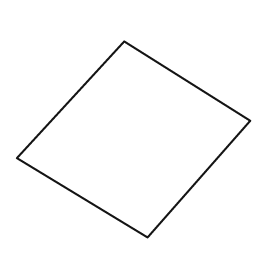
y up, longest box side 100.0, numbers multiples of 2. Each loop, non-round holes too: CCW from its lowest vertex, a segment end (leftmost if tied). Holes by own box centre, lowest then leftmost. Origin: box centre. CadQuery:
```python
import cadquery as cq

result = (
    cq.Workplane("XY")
    .moveTo(6.0, -42.0)
    .lineTo(50.0, 8.0)
    .lineTo(-4.0, 42.0)
    .lineTo(-50.0, -8.0)
    .close()
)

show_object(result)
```